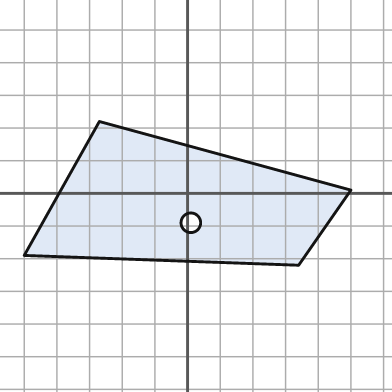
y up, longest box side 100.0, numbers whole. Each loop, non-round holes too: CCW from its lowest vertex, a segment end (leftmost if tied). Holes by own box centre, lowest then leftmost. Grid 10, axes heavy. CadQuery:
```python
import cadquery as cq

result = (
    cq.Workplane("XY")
    .moveTo(34.0, -22.0)
    .lineTo(50.0, 1.0)
    .lineTo(-27.0, 22.0)
    .lineTo(-50.0, -19.0)
    .close()
    .moveTo(1.0, -9.0)
    .circle(3.0)
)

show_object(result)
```